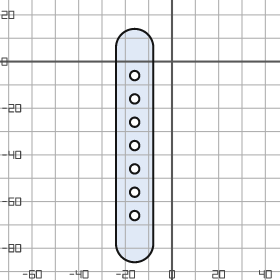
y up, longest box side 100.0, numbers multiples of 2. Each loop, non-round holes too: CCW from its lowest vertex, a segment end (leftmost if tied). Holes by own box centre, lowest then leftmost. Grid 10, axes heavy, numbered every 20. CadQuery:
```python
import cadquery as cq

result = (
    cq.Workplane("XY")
    .moveTo(-24.0, -78.0)
    .threePointArc((-16.0, -86.0), (-8.0, -78.0))
    .lineTo(-8.0, 6.0)
    .threePointArc((-16.0, 14.0), (-24.0, 6.0))
    .close()
    .moveTo(-16.0, -66.0)
    .circle(2.0)
    .moveTo(-16.0, -56.0)
    .circle(2.0)
    .moveTo(-16.0, -46.0)
    .circle(2.0)
    .moveTo(-16.0, -36.0)
    .circle(2.0)
    .moveTo(-16.0, -26.0)
    .circle(2.0)
    .moveTo(-16.0, -16.0)
    .circle(2.0)
    .moveTo(-16.0, -6.0)
    .circle(2.0)
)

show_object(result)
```